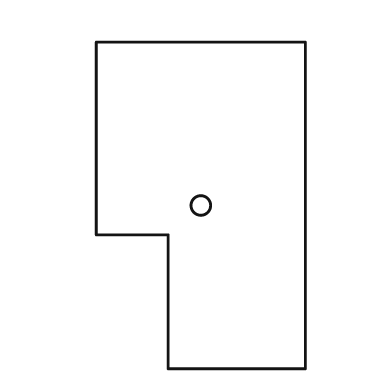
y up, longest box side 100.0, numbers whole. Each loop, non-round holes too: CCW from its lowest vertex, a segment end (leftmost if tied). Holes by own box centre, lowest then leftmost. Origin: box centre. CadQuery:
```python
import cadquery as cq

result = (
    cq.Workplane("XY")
    .moveTo(-10.0, -50.0)
    .lineTo(32.0, -50.0)
    .lineTo(32.0, 50.0)
    .lineTo(-32.0, 50.0)
    .lineTo(-32.0, -9.0)
    .lineTo(-10.0, -9.0)
    .close()
    .moveTo(0.0, 0.0)
    .circle(3.0)
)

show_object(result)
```